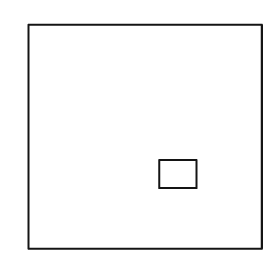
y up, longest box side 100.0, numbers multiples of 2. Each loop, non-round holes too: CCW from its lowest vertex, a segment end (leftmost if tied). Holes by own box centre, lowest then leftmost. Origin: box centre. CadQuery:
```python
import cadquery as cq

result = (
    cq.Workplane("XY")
    .moveTo(-50.0, -48.0)
    .lineTo(50.0, -48.0)
    .lineTo(50.0, 48.0)
    .lineTo(-50.0, 48.0)
    .close()
    .moveTo(6.0, -22.0)
    .lineTo(22.0, -22.0)
    .lineTo(22.0, -10.0)
    .lineTo(6.0, -10.0)
    .close()
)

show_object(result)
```